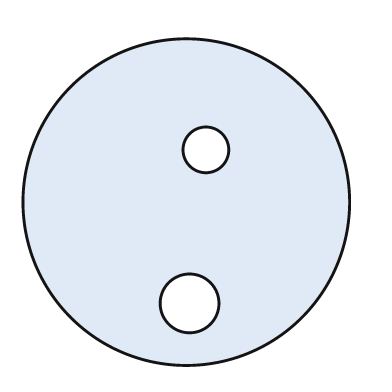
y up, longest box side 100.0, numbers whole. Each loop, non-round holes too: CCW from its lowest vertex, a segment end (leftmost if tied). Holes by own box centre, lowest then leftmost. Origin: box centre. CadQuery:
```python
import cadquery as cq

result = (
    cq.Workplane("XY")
    .moveTo(0.0, 0.0)
    .circle(50.0)
    .moveTo(1.0, -31.0)
    .circle(9.0)
    .moveTo(6.0, 16.0)
    .circle(7.0)
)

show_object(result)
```